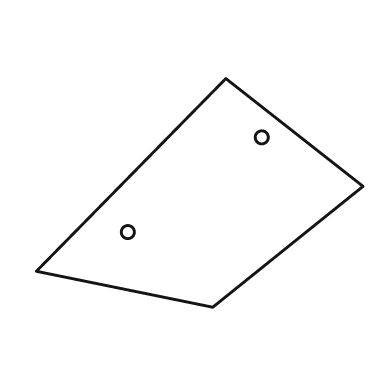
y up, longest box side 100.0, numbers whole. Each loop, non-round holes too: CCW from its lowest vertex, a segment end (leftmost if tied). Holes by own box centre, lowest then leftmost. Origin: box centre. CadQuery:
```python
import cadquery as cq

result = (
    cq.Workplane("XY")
    .moveTo(4.0, -35.0)
    .lineTo(50.0, 2.0)
    .lineTo(8.0, 35.0)
    .lineTo(-50.0, -24.0)
    .close()
    .moveTo(-22.0, -12.0)
    .circle(2.0)
    .moveTo(19.0, 17.0)
    .circle(2.0)
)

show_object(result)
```